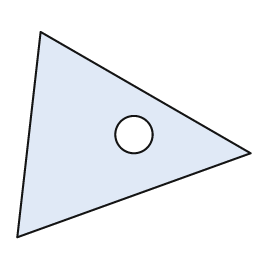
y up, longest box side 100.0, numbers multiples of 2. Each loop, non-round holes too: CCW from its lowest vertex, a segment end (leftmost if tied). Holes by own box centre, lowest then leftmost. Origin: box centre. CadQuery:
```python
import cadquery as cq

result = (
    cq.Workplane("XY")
    .moveTo(-50.0, -44.0)
    .lineTo(50.0, -8.0)
    .lineTo(-40.0, 44.0)
    .close()
    .moveTo(0.0, 0.0)
    .circle(8.0)
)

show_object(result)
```